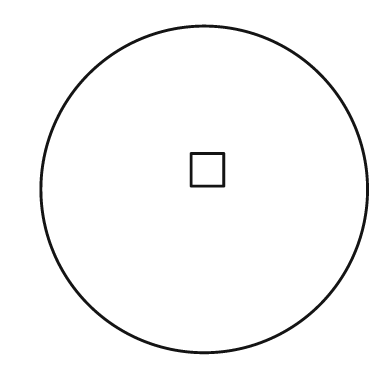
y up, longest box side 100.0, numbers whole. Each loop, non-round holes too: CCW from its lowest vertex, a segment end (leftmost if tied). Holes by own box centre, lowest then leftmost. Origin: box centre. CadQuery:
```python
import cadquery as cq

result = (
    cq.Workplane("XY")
    .moveTo(0.0, 0.0)
    .circle(50.0)
    .moveTo(-4.0, 1.0)
    .lineTo(6.0, 1.0)
    .lineTo(6.0, 11.0)
    .lineTo(-4.0, 11.0)
    .close()
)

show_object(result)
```